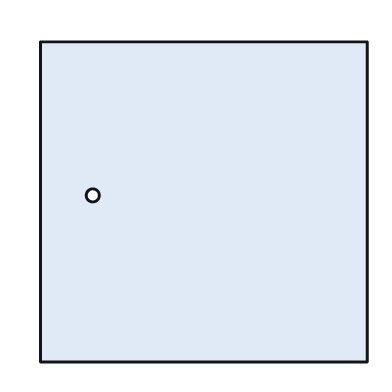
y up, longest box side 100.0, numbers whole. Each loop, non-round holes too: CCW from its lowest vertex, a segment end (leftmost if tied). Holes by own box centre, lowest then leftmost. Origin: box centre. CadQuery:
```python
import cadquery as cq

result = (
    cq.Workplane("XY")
    .moveTo(-50.0, -49.0)
    .lineTo(50.0, -49.0)
    .lineTo(50.0, 49.0)
    .lineTo(-50.0, 49.0)
    .close()
    .moveTo(-34.0, 2.0)
    .circle(2.0)
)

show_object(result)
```